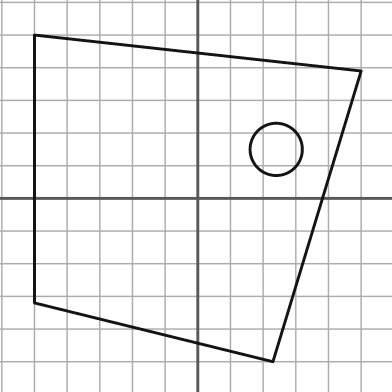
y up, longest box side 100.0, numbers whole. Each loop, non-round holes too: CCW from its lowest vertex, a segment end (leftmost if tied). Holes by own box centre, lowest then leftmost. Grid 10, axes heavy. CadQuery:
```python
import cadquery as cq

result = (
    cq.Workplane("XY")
    .moveTo(23.0, -50.0)
    .lineTo(50.0, 39.0)
    .lineTo(-50.0, 50.0)
    .lineTo(-50.0, -32.0)
    .close()
    .moveTo(24.0, 15.0)
    .circle(8.0)
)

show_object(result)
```